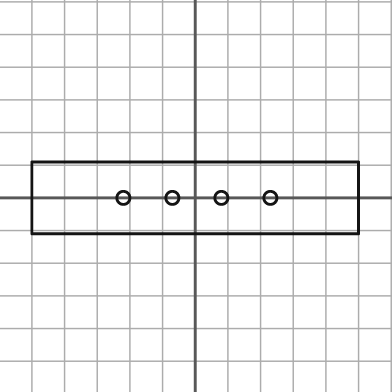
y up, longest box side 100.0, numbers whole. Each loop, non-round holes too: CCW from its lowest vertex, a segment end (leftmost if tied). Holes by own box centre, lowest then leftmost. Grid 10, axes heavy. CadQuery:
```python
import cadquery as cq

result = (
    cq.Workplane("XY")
    .moveTo(-50.0, -11.0)
    .lineTo(50.0, -11.0)
    .lineTo(50.0, 11.0)
    .lineTo(-50.0, 11.0)
    .close()
    .moveTo(-22.0, 0.0)
    .circle(2.0)
    .moveTo(-7.0, 0.0)
    .circle(2.0)
    .moveTo(8.0, 0.0)
    .circle(2.0)
    .moveTo(23.0, 0.0)
    .circle(2.0)
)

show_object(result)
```